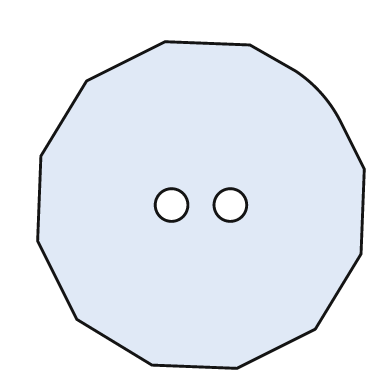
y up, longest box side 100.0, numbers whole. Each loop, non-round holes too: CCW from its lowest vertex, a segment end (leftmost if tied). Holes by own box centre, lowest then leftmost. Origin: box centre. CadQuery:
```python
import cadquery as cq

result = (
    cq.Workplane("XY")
    .moveTo(11.0, -50.0)
    .lineTo(35.0, -38.0)
    .lineTo(49.0, -15.0)
    .lineTo(50.0, 11.0)
    .lineTo(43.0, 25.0)
    .threePointArc((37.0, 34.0), (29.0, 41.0))
    .lineTo(15.0, 49.0)
    .lineTo(-11.0, 50.0)
    .lineTo(-35.0, 38.0)
    .lineTo(-49.0, 15.0)
    .lineTo(-50.0, -11.0)
    .lineTo(-38.0, -35.0)
    .lineTo(-15.0, -49.0)
    .close()
    .moveTo(-9.0, 0.0)
    .circle(5.0)
    .moveTo(9.0, 0.0)
    .circle(5.0)
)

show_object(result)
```